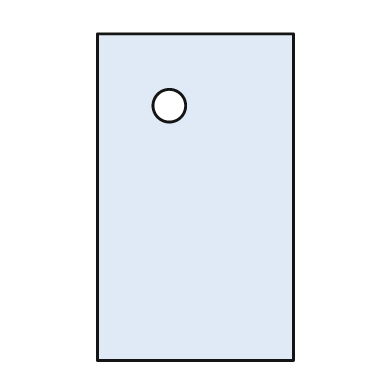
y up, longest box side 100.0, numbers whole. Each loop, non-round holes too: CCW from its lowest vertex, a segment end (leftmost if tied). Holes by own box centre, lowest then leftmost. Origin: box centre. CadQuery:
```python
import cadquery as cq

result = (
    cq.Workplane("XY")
    .moveTo(-30.0, -50.0)
    .lineTo(30.0, -50.0)
    .lineTo(30.0, 50.0)
    .lineTo(-30.0, 50.0)
    .close()
    .moveTo(-8.0, 28.0)
    .circle(5.0)
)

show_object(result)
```